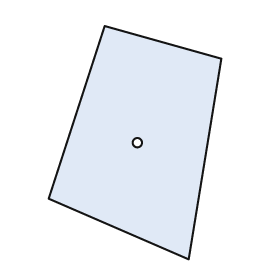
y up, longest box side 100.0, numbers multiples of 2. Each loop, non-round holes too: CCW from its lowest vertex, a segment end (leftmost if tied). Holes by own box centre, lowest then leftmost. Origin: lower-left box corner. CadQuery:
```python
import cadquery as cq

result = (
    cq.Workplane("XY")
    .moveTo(60.0, 0.0)
    .lineTo(74.0, 86.0)
    .lineTo(24.0, 100.0)
    .lineTo(0.0, 26.0)
    .close()
    .moveTo(38.0, 50.0)
    .circle(2.0)
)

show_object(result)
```